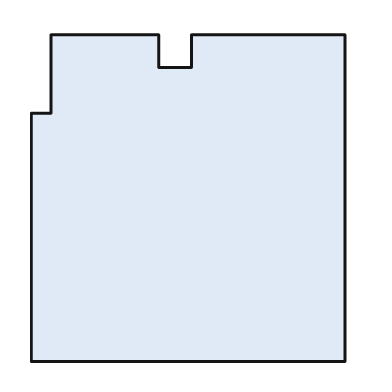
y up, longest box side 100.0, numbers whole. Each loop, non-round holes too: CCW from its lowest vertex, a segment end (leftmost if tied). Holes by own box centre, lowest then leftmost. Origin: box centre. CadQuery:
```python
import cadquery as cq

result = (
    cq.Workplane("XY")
    .moveTo(-48.0, -50.0)
    .lineTo(48.0, -50.0)
    .lineTo(48.0, 50.0)
    .lineTo(1.0, 50.0)
    .lineTo(1.0, 40.0)
    .lineTo(-9.0, 40.0)
    .lineTo(-9.0, 50.0)
    .lineTo(-42.0, 50.0)
    .lineTo(-42.0, 26.0)
    .lineTo(-48.0, 26.0)
    .close()
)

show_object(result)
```